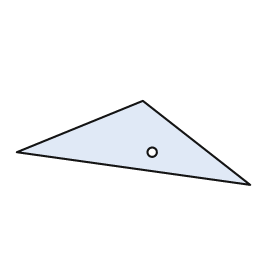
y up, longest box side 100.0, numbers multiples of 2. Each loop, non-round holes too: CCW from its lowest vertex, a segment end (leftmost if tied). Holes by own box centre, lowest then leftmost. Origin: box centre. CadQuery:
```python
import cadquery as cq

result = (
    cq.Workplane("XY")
    .moveTo(50.0, -18.0)
    .lineTo(4.0, 18.0)
    .lineTo(-50.0, -4.0)
    .close()
    .moveTo(8.0, -4.0)
    .circle(2.0)
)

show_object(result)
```